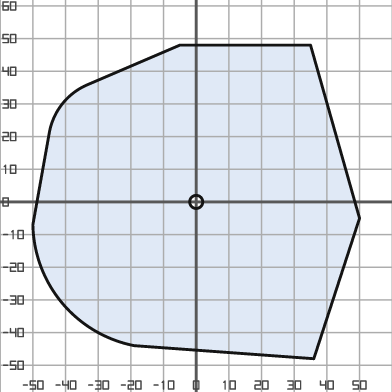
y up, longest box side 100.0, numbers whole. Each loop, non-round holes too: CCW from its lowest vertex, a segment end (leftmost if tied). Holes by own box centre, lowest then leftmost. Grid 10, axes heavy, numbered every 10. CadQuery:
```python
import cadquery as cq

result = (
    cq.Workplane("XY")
    .moveTo(36.0, -48.0)
    .lineTo(50.0, -5.0)
    .lineTo(35.0, 48.0)
    .lineTo(-5.0, 48.0)
    .lineTo(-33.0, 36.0)
    .threePointArc((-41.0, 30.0), (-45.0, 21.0))
    .lineTo(-50.0, -7.0)
    .threePointArc((-41.0, -31.0), (-19.0, -44.0))
    .close()
    .moveTo(0.0, 0.0)
    .circle(2.0)
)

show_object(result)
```